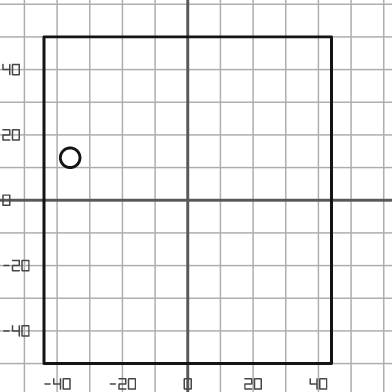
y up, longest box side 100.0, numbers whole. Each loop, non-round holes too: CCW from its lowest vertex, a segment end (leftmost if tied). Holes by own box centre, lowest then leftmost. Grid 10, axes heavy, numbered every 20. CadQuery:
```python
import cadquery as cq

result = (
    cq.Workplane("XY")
    .moveTo(-44.0, -50.0)
    .lineTo(44.0, -50.0)
    .lineTo(44.0, 50.0)
    .lineTo(-44.0, 50.0)
    .close()
    .moveTo(-36.0, 13.0)
    .circle(3.0)
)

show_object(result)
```